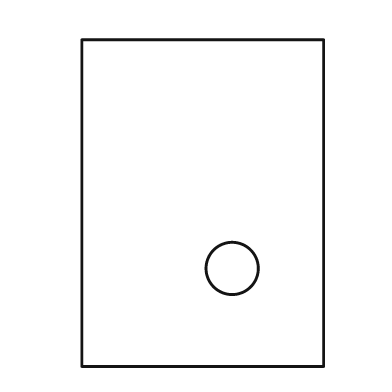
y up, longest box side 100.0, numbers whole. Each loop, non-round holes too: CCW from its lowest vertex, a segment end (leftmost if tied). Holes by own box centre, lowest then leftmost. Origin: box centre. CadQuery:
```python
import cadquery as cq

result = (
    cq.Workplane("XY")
    .moveTo(-37.0, -50.0)
    .lineTo(37.0, -50.0)
    .lineTo(37.0, 50.0)
    .lineTo(-37.0, 50.0)
    .close()
    .moveTo(9.0, -20.0)
    .circle(8.0)
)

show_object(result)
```